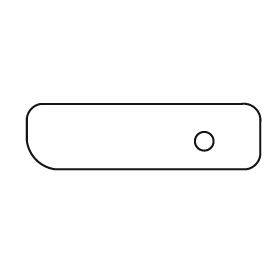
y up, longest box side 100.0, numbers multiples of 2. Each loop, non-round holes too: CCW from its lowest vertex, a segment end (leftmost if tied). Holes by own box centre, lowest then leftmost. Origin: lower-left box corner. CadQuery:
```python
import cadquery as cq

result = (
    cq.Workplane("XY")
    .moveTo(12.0, 0.0)
    .lineTo(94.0, 0.0)
    .threePointArc((98.0, 2.0), (100.0, 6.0))
    .lineTo(100.0, 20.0)
    .threePointArc((98.0, 26.0), (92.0, 28.0))
    .lineTo(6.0, 28.0)
    .threePointArc((2.0, 26.0), (0.0, 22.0))
    .lineTo(0.0, 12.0)
    .threePointArc((4.0, 4.0), (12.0, 0.0))
    .close()
    .moveTo(76.0, 12.0)
    .circle(4.0)
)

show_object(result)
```